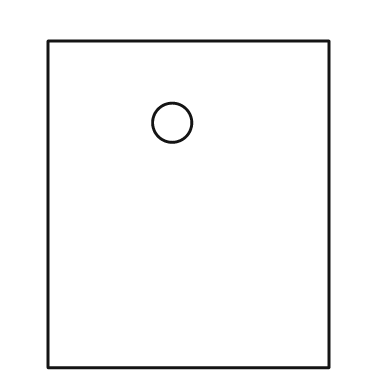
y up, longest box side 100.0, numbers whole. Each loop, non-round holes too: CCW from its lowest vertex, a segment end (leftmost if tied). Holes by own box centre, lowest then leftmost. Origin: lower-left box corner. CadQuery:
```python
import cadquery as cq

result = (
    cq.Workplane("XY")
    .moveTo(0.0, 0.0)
    .lineTo(86.0, 0.0)
    .lineTo(86.0, 100.0)
    .lineTo(0.0, 100.0)
    .close()
    .moveTo(38.0, 75.0)
    .circle(6.0)
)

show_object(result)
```